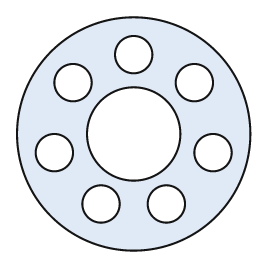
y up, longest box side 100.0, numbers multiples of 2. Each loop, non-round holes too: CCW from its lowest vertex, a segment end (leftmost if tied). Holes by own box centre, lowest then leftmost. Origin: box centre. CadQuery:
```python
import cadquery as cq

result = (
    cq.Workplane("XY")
    .moveTo(0.0, 0.0)
    .circle(50.0)
    .moveTo(-14.0, -30.0)
    .circle(8.0)
    .moveTo(14.0, -30.0)
    .circle(8.0)
    .moveTo(-34.0, -8.0)
    .circle(8.0)
    .moveTo(34.0, -8.0)
    .circle(8.0)
    .moveTo(0.0, 0.0)
    .circle(20.0)
    .moveTo(-26.0, 22.0)
    .circle(8.0)
    .moveTo(26.0, 22.0)
    .circle(8.0)
    .moveTo(0.0, 34.0)
    .circle(8.0)
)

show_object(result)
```